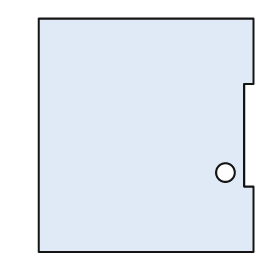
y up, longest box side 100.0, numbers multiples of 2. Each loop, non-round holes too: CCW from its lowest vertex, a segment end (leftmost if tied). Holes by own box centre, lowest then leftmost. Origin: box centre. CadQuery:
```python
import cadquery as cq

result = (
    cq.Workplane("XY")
    .moveTo(-46.0, -50.0)
    .lineTo(46.0, -50.0)
    .lineTo(46.0, -22.0)
    .lineTo(42.0, -22.0)
    .lineTo(42.0, 22.0)
    .lineTo(46.0, 22.0)
    .lineTo(46.0, 50.0)
    .lineTo(-46.0, 50.0)
    .close()
    .moveTo(34.0, -16.0)
    .circle(4.0)
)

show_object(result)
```